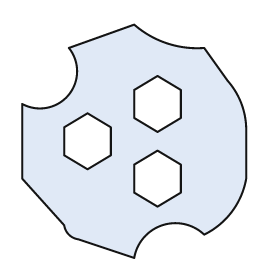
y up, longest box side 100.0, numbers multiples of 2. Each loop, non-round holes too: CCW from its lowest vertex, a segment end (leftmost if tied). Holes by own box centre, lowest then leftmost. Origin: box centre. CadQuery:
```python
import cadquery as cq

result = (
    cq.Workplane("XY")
    .moveTo(0.0, -50.0)
    .threePointArc((12.0, -36.0), (30.0, -40.0))
    .threePointArc((42.0, -30.0), (48.0, -16.0))
    .lineTo(48.0, 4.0)
    .threePointArc((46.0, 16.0), (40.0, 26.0))
    .lineTo(30.0, 40.0)
    .threePointArc((14.0, 42.0), (0.0, 50.0))
    .lineTo(-28.0, 40.0)
    .threePointArc((-28.0, 20.0), (-48.0, 16.0))
    .lineTo(-48.0, -16.0)
    .lineTo(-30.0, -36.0)
    .threePointArc((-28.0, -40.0), (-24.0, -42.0))
    .close()
    .moveTo(10.0, -28.0)
    .lineTo(20.0, -22.0)
    .lineTo(20.0, -10.0)
    .lineTo(10.0, -4.0)
    .lineTo(0.0, -10.0)
    .lineTo(0.0, -22.0)
    .close()
    .moveTo(-20.0, -12.0)
    .lineTo(-10.0, -6.0)
    .lineTo(-10.0, 6.0)
    .lineTo(-20.0, 12.0)
    .lineTo(-30.0, 6.0)
    .lineTo(-30.0, -6.0)
    .close()
    .moveTo(10.0, 4.0)
    .lineTo(20.0, 10.0)
    .lineTo(20.0, 22.0)
    .lineTo(10.0, 28.0)
    .lineTo(0.0, 22.0)
    .lineTo(0.0, 10.0)
    .close()
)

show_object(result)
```